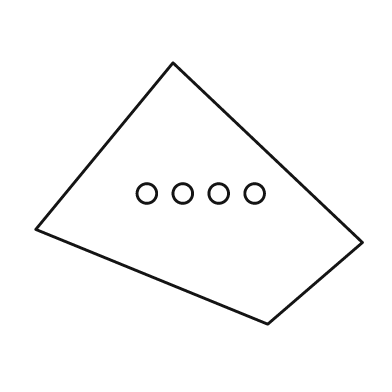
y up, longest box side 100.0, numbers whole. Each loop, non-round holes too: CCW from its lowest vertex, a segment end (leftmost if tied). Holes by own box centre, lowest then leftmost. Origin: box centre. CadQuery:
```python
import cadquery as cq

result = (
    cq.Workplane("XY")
    .moveTo(21.0, -40.0)
    .lineTo(50.0, -15.0)
    .lineTo(-8.0, 40.0)
    .lineTo(-50.0, -11.0)
    .close()
    .moveTo(-16.0, 0.0)
    .circle(3.0)
    .moveTo(-5.0, 0.0)
    .circle(3.0)
    .moveTo(6.0, 0.0)
    .circle(3.0)
    .moveTo(17.0, 0.0)
    .circle(3.0)
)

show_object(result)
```